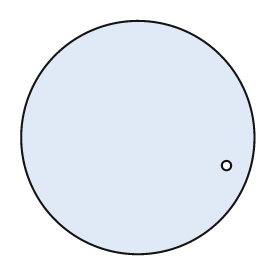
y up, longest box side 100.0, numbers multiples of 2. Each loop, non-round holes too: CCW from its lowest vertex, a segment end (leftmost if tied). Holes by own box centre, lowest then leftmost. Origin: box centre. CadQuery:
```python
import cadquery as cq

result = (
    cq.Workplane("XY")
    .moveTo(0.0, 0.0)
    .circle(50.0)
    .moveTo(38.0, -12.0)
    .circle(2.0)
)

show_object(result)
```